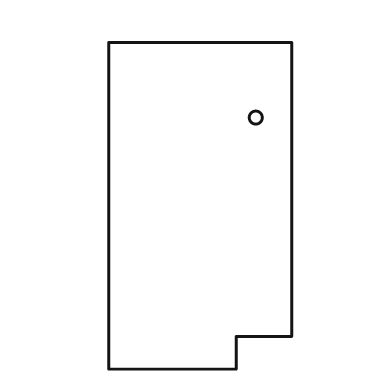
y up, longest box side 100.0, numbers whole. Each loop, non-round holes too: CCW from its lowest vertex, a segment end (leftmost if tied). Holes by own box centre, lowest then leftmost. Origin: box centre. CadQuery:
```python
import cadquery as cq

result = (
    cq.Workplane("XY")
    .moveTo(-28.0, -50.0)
    .lineTo(11.0, -50.0)
    .lineTo(11.0, -40.0)
    .lineTo(28.0, -40.0)
    .lineTo(28.0, 50.0)
    .lineTo(-28.0, 50.0)
    .close()
    .moveTo(17.0, 27.0)
    .circle(2.0)
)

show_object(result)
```